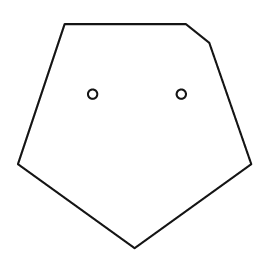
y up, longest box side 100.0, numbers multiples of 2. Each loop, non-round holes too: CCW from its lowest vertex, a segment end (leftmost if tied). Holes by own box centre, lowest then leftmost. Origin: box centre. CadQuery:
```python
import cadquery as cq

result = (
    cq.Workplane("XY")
    .moveTo(0.0, -48.0)
    .lineTo(50.0, -12.0)
    .lineTo(32.0, 40.0)
    .lineTo(22.0, 48.0)
    .lineTo(-30.0, 48.0)
    .lineTo(-50.0, -12.0)
    .close()
    .moveTo(-18.0, 18.0)
    .circle(2.0)
    .moveTo(20.0, 18.0)
    .circle(2.0)
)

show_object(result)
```